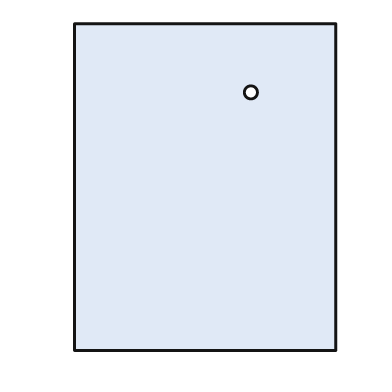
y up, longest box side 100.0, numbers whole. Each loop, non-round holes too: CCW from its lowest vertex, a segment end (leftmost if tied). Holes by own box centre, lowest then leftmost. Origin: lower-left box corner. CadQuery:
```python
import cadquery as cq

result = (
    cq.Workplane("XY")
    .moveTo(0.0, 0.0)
    .lineTo(80.0, 0.0)
    .lineTo(80.0, 100.0)
    .lineTo(0.0, 100.0)
    .close()
    .moveTo(54.0, 79.0)
    .circle(2.0)
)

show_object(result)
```